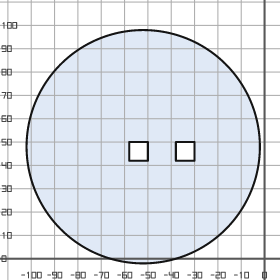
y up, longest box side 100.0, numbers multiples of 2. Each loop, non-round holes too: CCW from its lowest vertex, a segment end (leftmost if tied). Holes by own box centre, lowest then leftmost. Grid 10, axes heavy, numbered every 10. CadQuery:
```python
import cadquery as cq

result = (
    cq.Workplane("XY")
    .moveTo(-52.0, 48.0)
    .circle(50.0)
    .moveTo(-58.0, 42.0)
    .lineTo(-50.0, 42.0)
    .lineTo(-50.0, 50.0)
    .lineTo(-58.0, 50.0)
    .close()
    .moveTo(-38.0, 42.0)
    .lineTo(-30.0, 42.0)
    .lineTo(-30.0, 50.0)
    .lineTo(-38.0, 50.0)
    .close()
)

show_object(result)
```